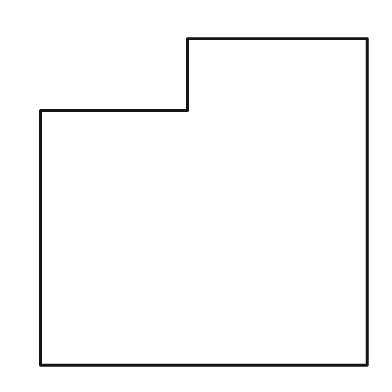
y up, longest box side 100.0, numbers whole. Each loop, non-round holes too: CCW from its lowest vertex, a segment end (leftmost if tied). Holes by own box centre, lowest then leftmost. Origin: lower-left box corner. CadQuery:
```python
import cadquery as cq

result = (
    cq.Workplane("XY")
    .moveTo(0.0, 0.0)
    .lineTo(100.0, 0.0)
    .lineTo(100.0, 100.0)
    .lineTo(45.0, 100.0)
    .lineTo(45.0, 78.0)
    .lineTo(0.0, 78.0)
    .close()
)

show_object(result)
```